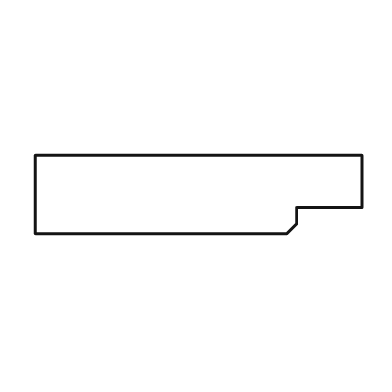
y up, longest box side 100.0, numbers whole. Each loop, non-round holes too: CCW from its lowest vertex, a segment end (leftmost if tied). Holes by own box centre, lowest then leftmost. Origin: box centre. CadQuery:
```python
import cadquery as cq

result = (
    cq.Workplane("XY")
    .moveTo(-50.0, -12.0)
    .lineTo(27.0, -12.0)
    .lineTo(30.0, -9.0)
    .lineTo(30.0, -4.0)
    .lineTo(50.0, -4.0)
    .lineTo(50.0, 12.0)
    .lineTo(-50.0, 12.0)
    .close()
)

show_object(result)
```